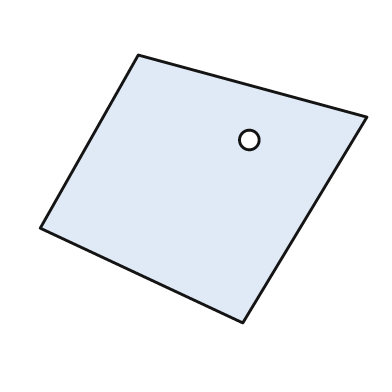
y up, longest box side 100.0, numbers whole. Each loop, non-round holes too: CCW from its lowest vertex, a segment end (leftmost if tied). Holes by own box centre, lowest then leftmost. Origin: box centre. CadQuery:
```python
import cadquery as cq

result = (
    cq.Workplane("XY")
    .moveTo(12.0, -41.0)
    .lineTo(50.0, 22.0)
    .lineTo(-20.0, 41.0)
    .lineTo(-50.0, -12.0)
    .close()
    .moveTo(14.0, 15.0)
    .circle(3.0)
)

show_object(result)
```